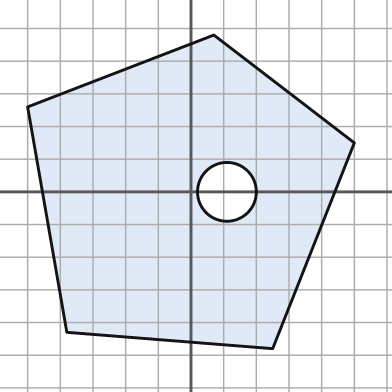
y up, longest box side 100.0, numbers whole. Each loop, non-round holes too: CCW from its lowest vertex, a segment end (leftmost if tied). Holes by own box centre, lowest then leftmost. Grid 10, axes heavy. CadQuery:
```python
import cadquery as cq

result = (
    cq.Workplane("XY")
    .moveTo(25.0, -48.0)
    .lineTo(50.0, 15.0)
    .lineTo(7.0, 48.0)
    .lineTo(-50.0, 26.0)
    .lineTo(-38.0, -43.0)
    .close()
    .moveTo(11.0, 0.0)
    .circle(9.0)
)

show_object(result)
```